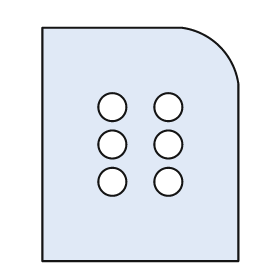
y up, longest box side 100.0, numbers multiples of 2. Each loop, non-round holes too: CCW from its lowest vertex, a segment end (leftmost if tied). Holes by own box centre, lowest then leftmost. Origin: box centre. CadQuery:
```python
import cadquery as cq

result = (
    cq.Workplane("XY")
    .moveTo(-42.0, -50.0)
    .lineTo(42.0, -50.0)
    .lineTo(42.0, 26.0)
    .threePointArc((34.0, 42.0), (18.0, 50.0))
    .lineTo(-42.0, 50.0)
    .close()
    .moveTo(-12.0, -16.0)
    .circle(6.0)
    .moveTo(12.0, -16.0)
    .circle(6.0)
    .moveTo(-12.0, 0.0)
    .circle(6.0)
    .moveTo(12.0, 0.0)
    .circle(6.0)
    .moveTo(-12.0, 16.0)
    .circle(6.0)
    .moveTo(12.0, 16.0)
    .circle(6.0)
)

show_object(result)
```